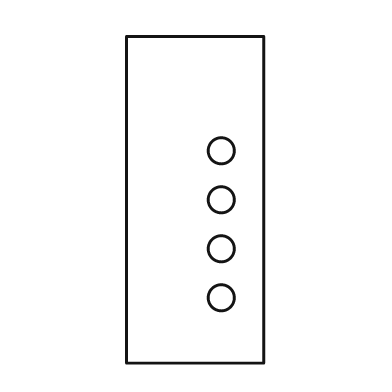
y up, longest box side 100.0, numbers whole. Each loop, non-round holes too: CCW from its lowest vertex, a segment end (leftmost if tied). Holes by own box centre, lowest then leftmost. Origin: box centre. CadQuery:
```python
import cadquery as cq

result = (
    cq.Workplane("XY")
    .moveTo(-21.0, -50.0)
    .lineTo(21.0, -50.0)
    .lineTo(21.0, 50.0)
    .lineTo(-21.0, 50.0)
    .close()
    .moveTo(8.0, -30.0)
    .circle(4.0)
    .moveTo(8.0, -15.0)
    .circle(4.0)
    .moveTo(8.0, 0.0)
    .circle(4.0)
    .moveTo(8.0, 15.0)
    .circle(4.0)
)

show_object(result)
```